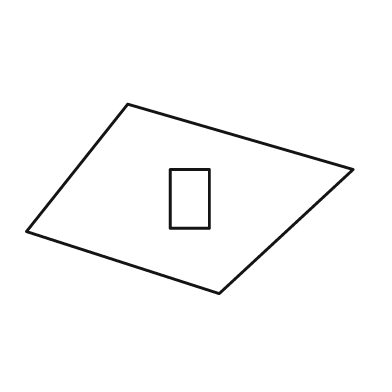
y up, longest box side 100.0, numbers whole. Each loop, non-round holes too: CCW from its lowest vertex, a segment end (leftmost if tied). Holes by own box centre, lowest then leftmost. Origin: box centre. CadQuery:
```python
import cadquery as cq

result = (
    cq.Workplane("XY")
    .moveTo(9.0, -29.0)
    .lineTo(50.0, 9.0)
    .lineTo(-19.0, 29.0)
    .lineTo(-50.0, -10.0)
    .close()
    .moveTo(-6.0, -9.0)
    .lineTo(6.0, -9.0)
    .lineTo(6.0, 9.0)
    .lineTo(-6.0, 9.0)
    .close()
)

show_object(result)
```